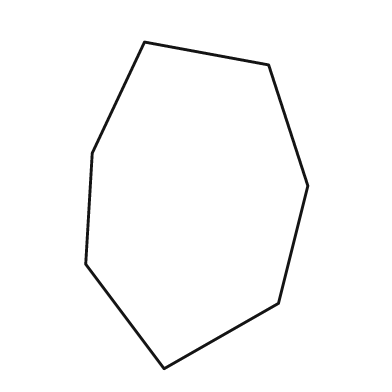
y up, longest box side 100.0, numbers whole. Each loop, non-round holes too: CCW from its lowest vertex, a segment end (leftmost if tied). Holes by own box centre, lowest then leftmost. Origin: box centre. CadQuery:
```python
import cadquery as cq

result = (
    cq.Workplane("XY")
    .moveTo(-10.0, -50.0)
    .lineTo(25.0, -30.0)
    .lineTo(34.0, 6.0)
    .lineTo(22.0, 43.0)
    .lineTo(-16.0, 50.0)
    .lineTo(-32.0, 16.0)
    .lineTo(-34.0, -18.0)
    .close()
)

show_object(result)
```